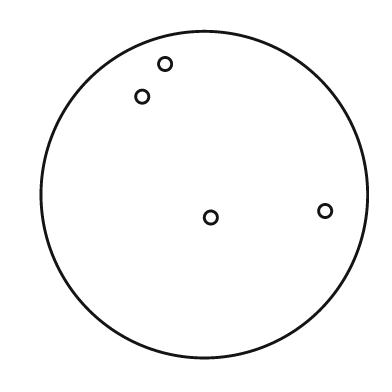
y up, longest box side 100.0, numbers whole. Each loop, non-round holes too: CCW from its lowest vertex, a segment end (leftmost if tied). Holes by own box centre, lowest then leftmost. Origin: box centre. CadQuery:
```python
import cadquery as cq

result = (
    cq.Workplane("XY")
    .moveTo(0.0, 0.0)
    .circle(50.0)
    .moveTo(2.0, -7.0)
    .circle(2.0)
    .moveTo(37.0, -5.0)
    .circle(2.0)
    .moveTo(-19.0, 30.0)
    .circle(2.0)
    .moveTo(-12.0, 40.0)
    .circle(2.0)
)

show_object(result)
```